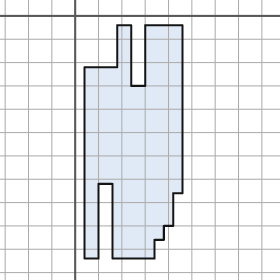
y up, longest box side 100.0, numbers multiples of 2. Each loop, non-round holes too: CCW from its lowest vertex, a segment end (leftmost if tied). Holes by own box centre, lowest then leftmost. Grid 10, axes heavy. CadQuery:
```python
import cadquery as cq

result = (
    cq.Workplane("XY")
    .moveTo(4.0, -104.0)
    .lineTo(10.0, -104.0)
    .lineTo(10.0, -72.0)
    .lineTo(16.0, -72.0)
    .lineTo(16.0, -104.0)
    .lineTo(34.0, -104.0)
    .lineTo(34.0, -96.0)
    .lineTo(38.0, -96.0)
    .lineTo(38.0, -90.0)
    .lineTo(42.0, -90.0)
    .lineTo(42.0, -76.0)
    .lineTo(46.0, -76.0)
    .lineTo(46.0, -4.0)
    .lineTo(30.0, -4.0)
    .lineTo(30.0, -30.0)
    .lineTo(24.0, -30.0)
    .lineTo(24.0, -4.0)
    .lineTo(18.0, -4.0)
    .lineTo(18.0, -22.0)
    .lineTo(4.0, -22.0)
    .close()
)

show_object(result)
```